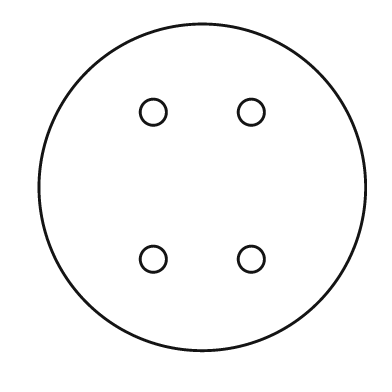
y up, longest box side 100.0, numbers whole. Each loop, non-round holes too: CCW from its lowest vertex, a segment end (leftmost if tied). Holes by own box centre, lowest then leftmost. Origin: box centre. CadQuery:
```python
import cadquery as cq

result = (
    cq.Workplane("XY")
    .moveTo(0.0, 0.0)
    .circle(50.0)
    .moveTo(-15.0, -22.0)
    .circle(4.0)
    .moveTo(15.0, -22.0)
    .circle(4.0)
    .moveTo(-15.0, 23.0)
    .circle(4.0)
    .moveTo(15.0, 23.0)
    .circle(4.0)
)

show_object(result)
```